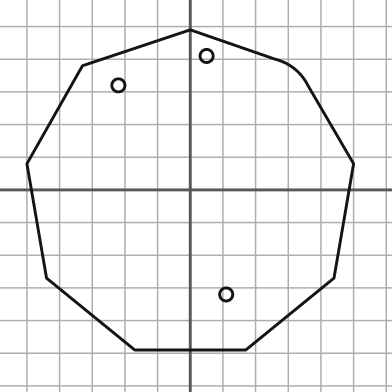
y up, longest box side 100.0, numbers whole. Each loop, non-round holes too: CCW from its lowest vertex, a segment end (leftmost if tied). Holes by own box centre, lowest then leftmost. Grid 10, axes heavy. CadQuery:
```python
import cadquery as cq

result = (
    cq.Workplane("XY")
    .moveTo(-17.0, -49.0)
    .lineTo(17.0, -49.0)
    .lineTo(44.0, -27.0)
    .lineTo(50.0, 8.0)
    .lineTo(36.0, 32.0)
    .threePointArc((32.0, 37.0), (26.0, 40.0))
    .lineTo(0.0, 49.0)
    .lineTo(-33.0, 38.0)
    .lineTo(-50.0, 8.0)
    .lineTo(-44.0, -27.0)
    .close()
    .moveTo(11.0, -32.0)
    .circle(2.0)
    .moveTo(-22.0, 32.0)
    .circle(2.0)
    .moveTo(5.0, 41.0)
    .circle(2.0)
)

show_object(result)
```